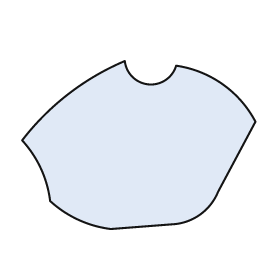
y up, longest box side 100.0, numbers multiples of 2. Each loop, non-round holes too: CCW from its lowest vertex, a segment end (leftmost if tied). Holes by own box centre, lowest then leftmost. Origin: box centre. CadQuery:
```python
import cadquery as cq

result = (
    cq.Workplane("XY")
    .moveTo(-12.0, -36.0)
    .lineTo(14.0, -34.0)
    .threePointArc((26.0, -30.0), (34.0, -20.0))
    .lineTo(50.0, 10.0)
    .threePointArc((36.0, 26.0), (16.0, 34.0))
    .threePointArc((4.0, 26.0), (-6.0, 36.0))
    .threePointArc((-30.0, 22.0), (-50.0, 2.0))
    .threePointArc((-42.0, -10.0), (-38.0, -24.0))
    .threePointArc((-26.0, -32.0), (-12.0, -36.0))
    .close()
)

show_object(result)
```